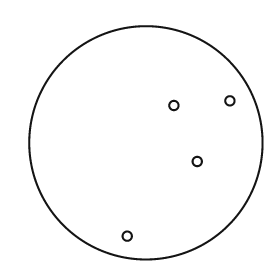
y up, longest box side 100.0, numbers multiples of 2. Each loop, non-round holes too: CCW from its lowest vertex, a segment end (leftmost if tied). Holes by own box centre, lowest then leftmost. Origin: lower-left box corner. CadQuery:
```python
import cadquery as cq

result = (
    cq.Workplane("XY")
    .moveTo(50.0, 50.0)
    .circle(50.0)
    .moveTo(42.0, 10.0)
    .circle(2.0)
    .moveTo(72.0, 42.0)
    .circle(2.0)
    .moveTo(62.0, 66.0)
    .circle(2.0)
    .moveTo(86.0, 68.0)
    .circle(2.0)
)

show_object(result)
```